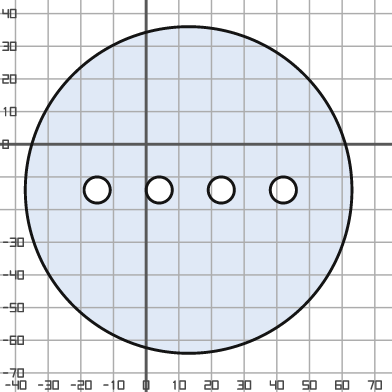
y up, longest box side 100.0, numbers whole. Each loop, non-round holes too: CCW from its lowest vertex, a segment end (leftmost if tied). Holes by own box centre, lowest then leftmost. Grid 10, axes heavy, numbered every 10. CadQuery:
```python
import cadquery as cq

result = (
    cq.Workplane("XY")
    .moveTo(13.0, -14.0)
    .circle(50.0)
    .moveTo(-15.0, -14.0)
    .circle(4.0)
    .moveTo(4.0, -14.0)
    .circle(4.0)
    .moveTo(23.0, -14.0)
    .circle(4.0)
    .moveTo(42.0, -14.0)
    .circle(4.0)
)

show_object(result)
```